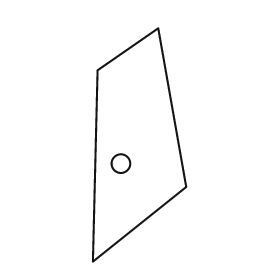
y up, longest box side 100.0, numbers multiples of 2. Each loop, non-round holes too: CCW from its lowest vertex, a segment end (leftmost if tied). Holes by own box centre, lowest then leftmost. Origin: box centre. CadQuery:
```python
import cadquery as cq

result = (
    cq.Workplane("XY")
    .moveTo(-20.0, -50.0)
    .lineTo(20.0, -18.0)
    .lineTo(8.0, 50.0)
    .lineTo(-18.0, 32.0)
    .close()
    .moveTo(-8.0, -8.0)
    .circle(4.0)
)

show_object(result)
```